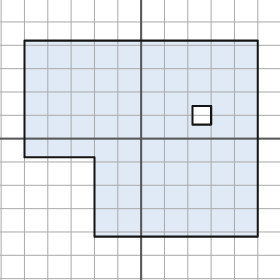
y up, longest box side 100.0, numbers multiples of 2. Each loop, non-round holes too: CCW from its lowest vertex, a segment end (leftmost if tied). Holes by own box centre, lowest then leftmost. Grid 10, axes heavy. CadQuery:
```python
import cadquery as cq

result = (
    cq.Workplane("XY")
    .moveTo(-20.0, -42.0)
    .lineTo(50.0, -42.0)
    .lineTo(50.0, 42.0)
    .lineTo(-50.0, 42.0)
    .lineTo(-50.0, -8.0)
    .lineTo(-20.0, -8.0)
    .close()
    .moveTo(22.0, 6.0)
    .lineTo(30.0, 6.0)
    .lineTo(30.0, 14.0)
    .lineTo(22.0, 14.0)
    .close()
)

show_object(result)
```